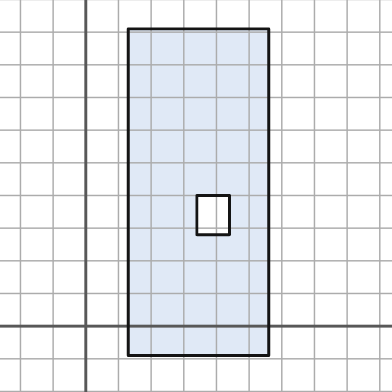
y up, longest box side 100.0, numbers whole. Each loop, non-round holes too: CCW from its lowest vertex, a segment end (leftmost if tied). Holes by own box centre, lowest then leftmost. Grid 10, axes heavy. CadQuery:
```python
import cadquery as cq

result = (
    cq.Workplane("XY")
    .moveTo(13.0, -9.0)
    .lineTo(56.0, -9.0)
    .lineTo(56.0, 91.0)
    .lineTo(13.0, 91.0)
    .close()
    .moveTo(34.0, 28.0)
    .lineTo(44.0, 28.0)
    .lineTo(44.0, 40.0)
    .lineTo(34.0, 40.0)
    .close()
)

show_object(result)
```